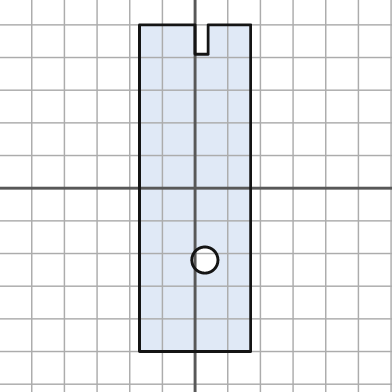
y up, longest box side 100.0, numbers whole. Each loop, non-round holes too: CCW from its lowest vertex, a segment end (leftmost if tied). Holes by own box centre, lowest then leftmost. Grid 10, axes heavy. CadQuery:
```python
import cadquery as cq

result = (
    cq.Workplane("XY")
    .moveTo(-17.0, -50.0)
    .lineTo(17.0, -50.0)
    .lineTo(17.0, 50.0)
    .lineTo(4.0, 50.0)
    .lineTo(4.0, 41.0)
    .lineTo(0.0, 41.0)
    .lineTo(0.0, 50.0)
    .lineTo(-17.0, 50.0)
    .close()
    .moveTo(3.0, -22.0)
    .circle(4.0)
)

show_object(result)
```